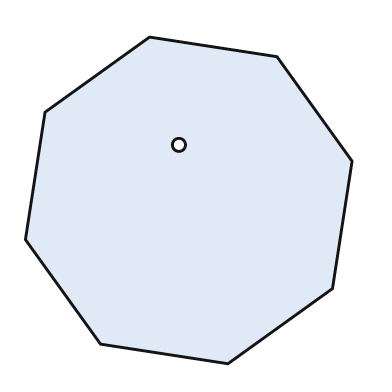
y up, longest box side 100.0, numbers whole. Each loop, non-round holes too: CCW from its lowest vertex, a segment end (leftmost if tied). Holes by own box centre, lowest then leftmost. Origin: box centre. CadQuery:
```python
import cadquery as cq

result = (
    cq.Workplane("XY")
    .moveTo(12.0, -50.0)
    .lineTo(44.0, -27.0)
    .lineTo(50.0, 12.0)
    .lineTo(27.0, 44.0)
    .lineTo(-12.0, 50.0)
    .lineTo(-44.0, 27.0)
    .lineTo(-50.0, -12.0)
    .lineTo(-27.0, -44.0)
    .close()
    .moveTo(-3.0, 17.0)
    .circle(2.0)
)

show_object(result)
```